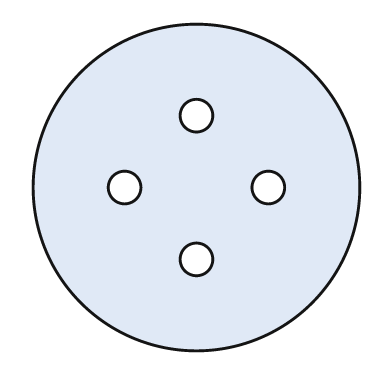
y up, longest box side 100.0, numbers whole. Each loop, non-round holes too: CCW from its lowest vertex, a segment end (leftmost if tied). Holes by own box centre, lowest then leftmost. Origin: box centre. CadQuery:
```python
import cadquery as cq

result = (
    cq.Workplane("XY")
    .moveTo(0.0, 0.0)
    .circle(50.0)
    .moveTo(0.0, -22.0)
    .circle(5.0)
    .moveTo(-22.0, 0.0)
    .circle(5.0)
    .moveTo(22.0, 0.0)
    .circle(5.0)
    .moveTo(0.0, 22.0)
    .circle(5.0)
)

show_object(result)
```